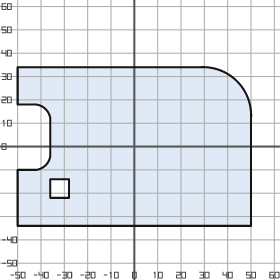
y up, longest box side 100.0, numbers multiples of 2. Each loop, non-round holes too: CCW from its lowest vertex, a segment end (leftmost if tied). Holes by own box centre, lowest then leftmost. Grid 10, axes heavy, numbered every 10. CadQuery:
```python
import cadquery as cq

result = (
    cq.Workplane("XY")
    .moveTo(-50.0, -34.0)
    .lineTo(50.0, -34.0)
    .lineTo(50.0, 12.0)
    .threePointArc((44.0, 28.0), (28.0, 34.0))
    .lineTo(-50.0, 34.0)
    .lineTo(-50.0, 18.0)
    .lineTo(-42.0, 18.0)
    .threePointArc((-38.0, 16.0), (-36.0, 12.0))
    .lineTo(-36.0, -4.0)
    .threePointArc((-38.0, -8.0), (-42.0, -10.0))
    .lineTo(-50.0, -10.0)
    .close()
    .moveTo(-36.0, -22.0)
    .lineTo(-28.0, -22.0)
    .lineTo(-28.0, -14.0)
    .lineTo(-36.0, -14.0)
    .close()
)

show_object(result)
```